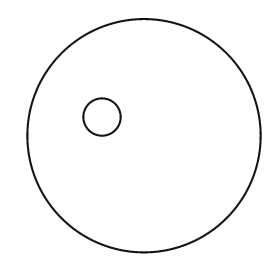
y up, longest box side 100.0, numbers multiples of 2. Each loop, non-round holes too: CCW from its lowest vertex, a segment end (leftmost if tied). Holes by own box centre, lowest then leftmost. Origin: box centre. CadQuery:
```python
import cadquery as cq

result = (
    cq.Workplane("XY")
    .moveTo(0.0, 0.0)
    .circle(50.0)
    .moveTo(-18.0, 8.0)
    .circle(8.0)
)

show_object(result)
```